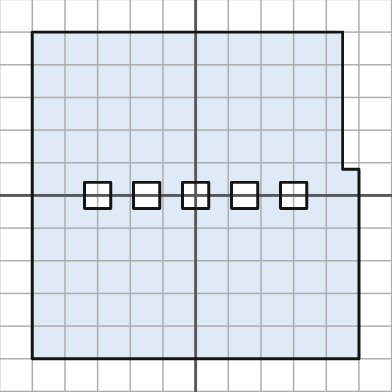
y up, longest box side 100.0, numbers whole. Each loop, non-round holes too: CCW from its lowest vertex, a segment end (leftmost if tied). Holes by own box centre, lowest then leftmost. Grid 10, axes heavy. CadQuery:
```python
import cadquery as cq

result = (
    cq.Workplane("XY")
    .moveTo(-50.0, -50.0)
    .lineTo(50.0, -50.0)
    .lineTo(50.0, 8.0)
    .lineTo(45.0, 8.0)
    .lineTo(45.0, 50.0)
    .lineTo(-50.0, 50.0)
    .close()
    .moveTo(-34.0, -4.0)
    .lineTo(-26.0, -4.0)
    .lineTo(-26.0, 4.0)
    .lineTo(-34.0, 4.0)
    .close()
    .moveTo(-19.0, -4.0)
    .lineTo(-11.0, -4.0)
    .lineTo(-11.0, 4.0)
    .lineTo(-19.0, 4.0)
    .close()
    .moveTo(-4.0, -4.0)
    .lineTo(4.0, -4.0)
    .lineTo(4.0, 4.0)
    .lineTo(-4.0, 4.0)
    .close()
    .moveTo(11.0, -4.0)
    .lineTo(19.0, -4.0)
    .lineTo(19.0, 4.0)
    .lineTo(11.0, 4.0)
    .close()
    .moveTo(26.0, -4.0)
    .lineTo(34.0, -4.0)
    .lineTo(34.0, 4.0)
    .lineTo(26.0, 4.0)
    .close()
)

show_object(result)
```